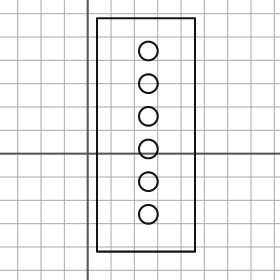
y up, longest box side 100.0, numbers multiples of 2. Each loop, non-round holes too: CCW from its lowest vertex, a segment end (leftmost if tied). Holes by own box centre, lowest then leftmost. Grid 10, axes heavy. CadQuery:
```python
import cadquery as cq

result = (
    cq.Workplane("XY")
    .moveTo(4.0, -42.0)
    .lineTo(46.0, -42.0)
    .lineTo(46.0, 58.0)
    .lineTo(4.0, 58.0)
    .close()
    .moveTo(26.0, -26.0)
    .circle(4.0)
    .moveTo(26.0, -12.0)
    .circle(4.0)
    .moveTo(26.0, 2.0)
    .circle(4.0)
    .moveTo(26.0, 16.0)
    .circle(4.0)
    .moveTo(26.0, 30.0)
    .circle(4.0)
    .moveTo(26.0, 44.0)
    .circle(4.0)
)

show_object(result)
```